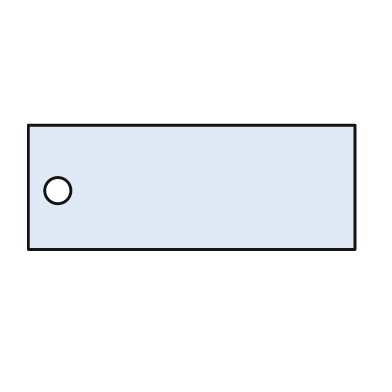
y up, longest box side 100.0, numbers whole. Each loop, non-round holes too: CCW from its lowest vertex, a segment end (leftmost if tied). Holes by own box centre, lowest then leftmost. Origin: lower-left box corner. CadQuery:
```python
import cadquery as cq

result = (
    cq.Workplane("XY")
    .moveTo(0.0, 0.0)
    .lineTo(100.0, 0.0)
    .lineTo(100.0, 38.0)
    .lineTo(0.0, 38.0)
    .close()
    .moveTo(9.0, 18.0)
    .circle(4.0)
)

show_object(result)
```